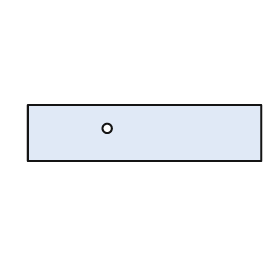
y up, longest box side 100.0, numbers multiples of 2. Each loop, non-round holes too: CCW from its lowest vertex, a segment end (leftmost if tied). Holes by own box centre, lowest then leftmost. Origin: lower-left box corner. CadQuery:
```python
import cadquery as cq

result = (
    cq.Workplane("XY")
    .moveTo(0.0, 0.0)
    .lineTo(100.0, 0.0)
    .lineTo(100.0, 24.0)
    .lineTo(0.0, 24.0)
    .close()
    .moveTo(34.0, 14.0)
    .circle(2.0)
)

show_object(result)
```